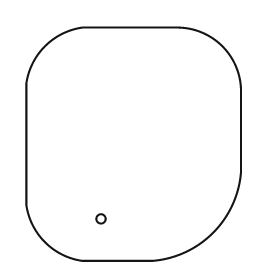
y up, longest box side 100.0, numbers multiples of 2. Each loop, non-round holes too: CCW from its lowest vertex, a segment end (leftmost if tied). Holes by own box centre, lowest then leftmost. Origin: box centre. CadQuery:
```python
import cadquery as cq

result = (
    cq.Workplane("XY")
    .moveTo(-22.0, -50.0)
    .lineTo(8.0, -50.0)
    .threePointArc((34.0, -38.0), (46.0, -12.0))
    .lineTo(46.0, 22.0)
    .threePointArc((38.0, 42.0), (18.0, 50.0))
    .lineTo(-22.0, 50.0)
    .threePointArc((-38.0, 42.0), (-46.0, 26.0))
    .lineTo(-46.0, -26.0)
    .threePointArc((-38.0, -42.0), (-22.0, -50.0))
    .close()
    .moveTo(-14.0, -32.0)
    .circle(2.0)
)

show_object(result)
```